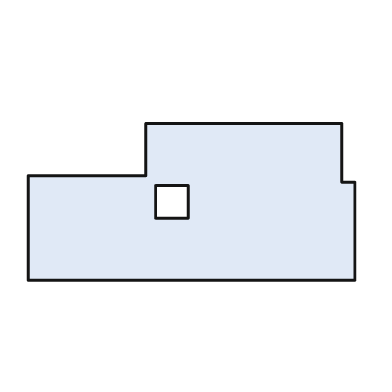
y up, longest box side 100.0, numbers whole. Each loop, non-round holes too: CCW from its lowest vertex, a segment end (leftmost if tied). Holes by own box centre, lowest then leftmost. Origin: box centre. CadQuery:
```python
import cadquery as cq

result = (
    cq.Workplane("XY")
    .moveTo(-50.0, -24.0)
    .lineTo(50.0, -24.0)
    .lineTo(50.0, 6.0)
    .lineTo(46.0, 6.0)
    .lineTo(46.0, 24.0)
    .lineTo(-14.0, 24.0)
    .lineTo(-14.0, 8.0)
    .lineTo(-50.0, 8.0)
    .close()
    .moveTo(-11.0, -5.0)
    .lineTo(-1.0, -5.0)
    .lineTo(-1.0, 5.0)
    .lineTo(-11.0, 5.0)
    .close()
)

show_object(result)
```